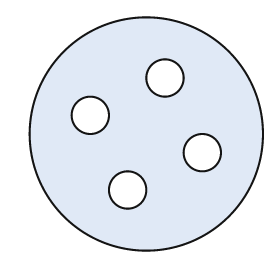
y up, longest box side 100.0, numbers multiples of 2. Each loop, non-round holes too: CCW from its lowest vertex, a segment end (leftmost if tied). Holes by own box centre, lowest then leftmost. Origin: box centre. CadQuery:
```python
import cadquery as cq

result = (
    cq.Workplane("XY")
    .moveTo(0.0, 0.0)
    .circle(50.0)
    .moveTo(-8.0, -24.0)
    .circle(8.0)
    .moveTo(24.0, -8.0)
    .circle(8.0)
    .moveTo(-24.0, 8.0)
    .circle(8.0)
    .moveTo(8.0, 24.0)
    .circle(8.0)
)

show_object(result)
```